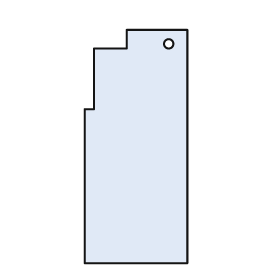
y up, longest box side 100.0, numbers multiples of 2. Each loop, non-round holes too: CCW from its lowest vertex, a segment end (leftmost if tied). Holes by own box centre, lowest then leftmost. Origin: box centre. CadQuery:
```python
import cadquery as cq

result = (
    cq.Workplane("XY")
    .moveTo(-22.0, -50.0)
    .lineTo(22.0, -50.0)
    .lineTo(22.0, 50.0)
    .lineTo(-4.0, 50.0)
    .lineTo(-4.0, 42.0)
    .lineTo(-18.0, 42.0)
    .lineTo(-18.0, 16.0)
    .lineTo(-22.0, 16.0)
    .close()
    .moveTo(14.0, 44.0)
    .circle(2.0)
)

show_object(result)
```